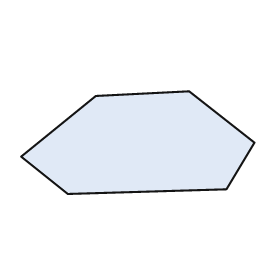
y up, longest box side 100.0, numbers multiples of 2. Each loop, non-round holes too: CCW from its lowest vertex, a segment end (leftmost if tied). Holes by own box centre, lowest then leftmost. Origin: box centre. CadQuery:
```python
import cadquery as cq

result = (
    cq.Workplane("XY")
    .moveTo(-30.0, -22.0)
    .lineTo(38.0, -20.0)
    .lineTo(50.0, 0.0)
    .lineTo(22.0, 22.0)
    .lineTo(-18.0, 20.0)
    .lineTo(-50.0, -6.0)
    .close()
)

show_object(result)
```